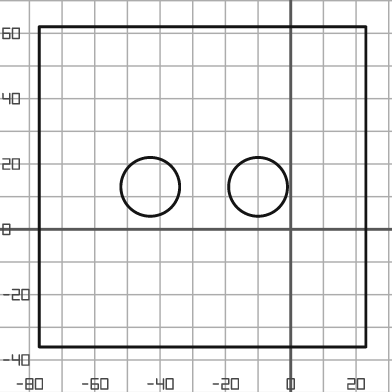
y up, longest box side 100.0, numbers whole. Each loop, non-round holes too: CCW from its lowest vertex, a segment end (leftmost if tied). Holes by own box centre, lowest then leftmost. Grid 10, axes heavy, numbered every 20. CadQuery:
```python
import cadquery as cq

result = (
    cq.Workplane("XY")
    .moveTo(-77.0, -36.0)
    .lineTo(23.0, -36.0)
    .lineTo(23.0, 62.0)
    .lineTo(-77.0, 62.0)
    .close()
    .moveTo(-43.0, 13.0)
    .circle(9.0)
    .moveTo(-10.0, 13.0)
    .circle(9.0)
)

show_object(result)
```